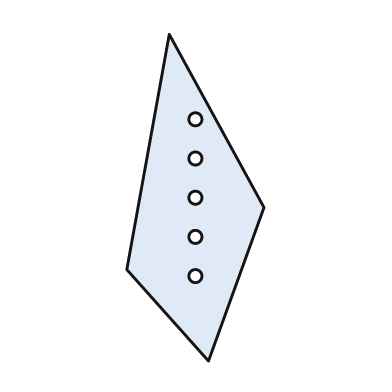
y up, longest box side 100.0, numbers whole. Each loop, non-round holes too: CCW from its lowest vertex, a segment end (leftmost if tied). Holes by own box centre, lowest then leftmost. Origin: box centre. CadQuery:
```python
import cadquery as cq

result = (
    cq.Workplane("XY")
    .moveTo(4.0, -50.0)
    .lineTo(21.0, -3.0)
    .lineTo(-8.0, 50.0)
    .lineTo(-21.0, -22.0)
    .close()
    .moveTo(0.0, -24.0)
    .circle(2.0)
    .moveTo(0.0, -12.0)
    .circle(2.0)
    .moveTo(0.0, 0.0)
    .circle(2.0)
    .moveTo(0.0, 12.0)
    .circle(2.0)
    .moveTo(0.0, 24.0)
    .circle(2.0)
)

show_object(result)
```